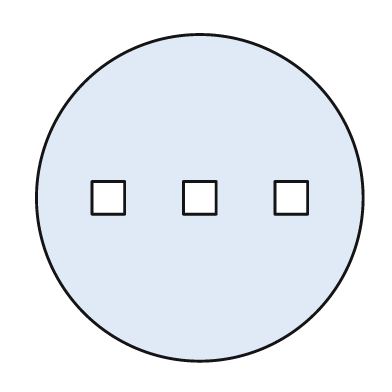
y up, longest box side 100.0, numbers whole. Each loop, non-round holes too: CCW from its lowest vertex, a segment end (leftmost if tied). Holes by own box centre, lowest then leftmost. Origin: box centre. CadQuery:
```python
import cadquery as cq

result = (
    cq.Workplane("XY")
    .moveTo(0.0, 0.0)
    .circle(50.0)
    .moveTo(-33.0, -5.0)
    .lineTo(-23.0, -5.0)
    .lineTo(-23.0, 5.0)
    .lineTo(-33.0, 5.0)
    .close()
    .moveTo(-5.0, -5.0)
    .lineTo(5.0, -5.0)
    .lineTo(5.0, 5.0)
    .lineTo(-5.0, 5.0)
    .close()
    .moveTo(23.0, -5.0)
    .lineTo(33.0, -5.0)
    .lineTo(33.0, 5.0)
    .lineTo(23.0, 5.0)
    .close()
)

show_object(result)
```